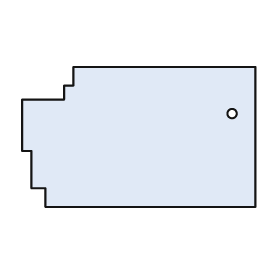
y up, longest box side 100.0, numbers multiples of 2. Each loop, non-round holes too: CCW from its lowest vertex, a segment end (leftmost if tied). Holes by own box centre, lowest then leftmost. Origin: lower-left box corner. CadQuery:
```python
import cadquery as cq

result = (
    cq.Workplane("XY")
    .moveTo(10.0, 0.0)
    .lineTo(100.0, 0.0)
    .lineTo(100.0, 60.0)
    .lineTo(22.0, 60.0)
    .lineTo(22.0, 52.0)
    .lineTo(18.0, 52.0)
    .lineTo(18.0, 46.0)
    .lineTo(0.0, 46.0)
    .lineTo(0.0, 24.0)
    .lineTo(4.0, 24.0)
    .lineTo(4.0, 8.0)
    .lineTo(10.0, 8.0)
    .close()
    .moveTo(90.0, 40.0)
    .circle(2.0)
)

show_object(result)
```